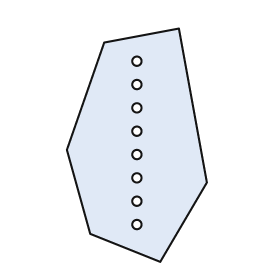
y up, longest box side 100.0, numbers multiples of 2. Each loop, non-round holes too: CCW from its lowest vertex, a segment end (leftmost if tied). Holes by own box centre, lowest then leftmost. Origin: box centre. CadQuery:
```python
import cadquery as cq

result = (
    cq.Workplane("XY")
    .moveTo(10.0, -50.0)
    .lineTo(30.0, -16.0)
    .lineTo(18.0, 50.0)
    .lineTo(-14.0, 44.0)
    .lineTo(-30.0, -2.0)
    .lineTo(-20.0, -38.0)
    .close()
    .moveTo(0.0, -34.0)
    .circle(2.0)
    .moveTo(0.0, -24.0)
    .circle(2.0)
    .moveTo(0.0, -14.0)
    .circle(2.0)
    .moveTo(0.0, -4.0)
    .circle(2.0)
    .moveTo(0.0, 6.0)
    .circle(2.0)
    .moveTo(0.0, 16.0)
    .circle(2.0)
    .moveTo(0.0, 26.0)
    .circle(2.0)
    .moveTo(0.0, 36.0)
    .circle(2.0)
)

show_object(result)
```